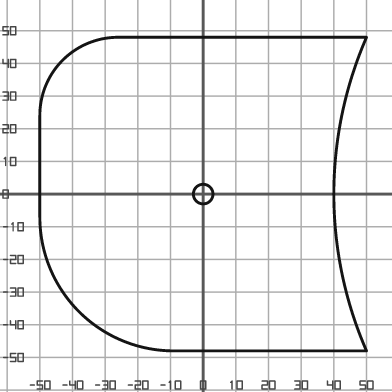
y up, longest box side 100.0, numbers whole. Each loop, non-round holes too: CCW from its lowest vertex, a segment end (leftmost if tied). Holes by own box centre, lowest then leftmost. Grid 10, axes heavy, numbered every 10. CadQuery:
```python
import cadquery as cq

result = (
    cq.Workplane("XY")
    .moveTo(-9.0, -48.0)
    .lineTo(50.0, -48.0)
    .threePointArc((40.0, 0.0), (50.0, 48.0))
    .lineTo(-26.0, 48.0)
    .threePointArc((-43.0, 41.0), (-50.0, 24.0))
    .lineTo(-50.0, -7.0)
    .threePointArc((-38.0, -36.0), (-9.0, -48.0))
    .close()
    .moveTo(0.0, 0.0)
    .circle(3.0)
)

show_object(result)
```